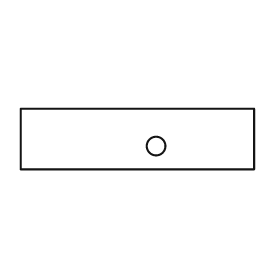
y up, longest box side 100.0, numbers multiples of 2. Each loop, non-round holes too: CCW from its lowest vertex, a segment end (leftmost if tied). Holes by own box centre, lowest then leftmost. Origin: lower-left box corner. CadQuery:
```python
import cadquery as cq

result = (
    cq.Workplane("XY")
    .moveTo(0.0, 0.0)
    .lineTo(100.0, 0.0)
    .lineTo(100.0, 26.0)
    .lineTo(0.0, 26.0)
    .close()
    .moveTo(58.0, 10.0)
    .circle(4.0)
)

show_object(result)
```